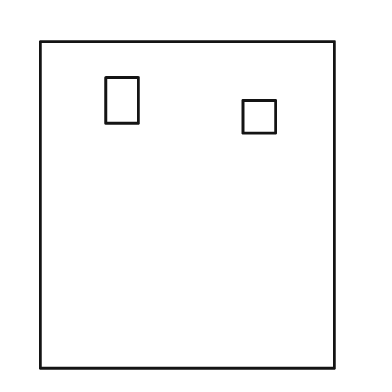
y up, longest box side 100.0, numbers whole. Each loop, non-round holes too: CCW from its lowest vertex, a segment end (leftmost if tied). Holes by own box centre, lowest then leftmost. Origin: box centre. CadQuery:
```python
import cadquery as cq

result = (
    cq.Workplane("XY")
    .moveTo(-45.0, -50.0)
    .lineTo(45.0, -50.0)
    .lineTo(45.0, 50.0)
    .lineTo(-45.0, 50.0)
    .close()
    .moveTo(17.0, 22.0)
    .lineTo(27.0, 22.0)
    .lineTo(27.0, 32.0)
    .lineTo(17.0, 32.0)
    .close()
    .moveTo(-25.0, 25.0)
    .lineTo(-15.0, 25.0)
    .lineTo(-15.0, 39.0)
    .lineTo(-25.0, 39.0)
    .close()
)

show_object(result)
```